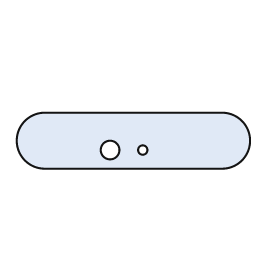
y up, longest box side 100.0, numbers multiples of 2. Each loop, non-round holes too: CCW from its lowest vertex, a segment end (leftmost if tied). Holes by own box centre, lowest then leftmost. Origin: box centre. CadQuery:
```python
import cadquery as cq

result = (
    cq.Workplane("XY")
    .moveTo(-38.0, -12.0)
    .lineTo(38.0, -12.0)
    .threePointArc((50.0, 0.0), (38.0, 12.0))
    .lineTo(-38.0, 12.0)
    .threePointArc((-50.0, 0.0), (-38.0, -12.0))
    .close()
    .moveTo(-10.0, -4.0)
    .circle(4.0)
    .moveTo(4.0, -4.0)
    .circle(2.0)
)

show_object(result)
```